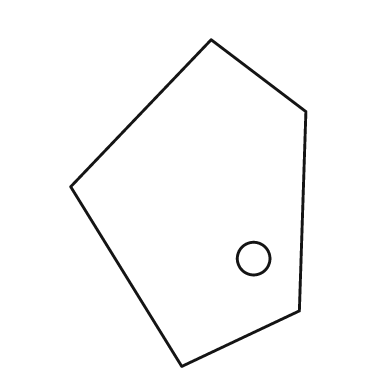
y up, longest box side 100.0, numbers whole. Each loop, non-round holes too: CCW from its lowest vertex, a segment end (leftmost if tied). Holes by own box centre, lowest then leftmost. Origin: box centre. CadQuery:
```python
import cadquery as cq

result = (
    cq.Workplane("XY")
    .moveTo(-2.0, -50.0)
    .lineTo(34.0, -33.0)
    .lineTo(36.0, 28.0)
    .lineTo(7.0, 50.0)
    .lineTo(-36.0, 5.0)
    .close()
    .moveTo(20.0, -17.0)
    .circle(5.0)
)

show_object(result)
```